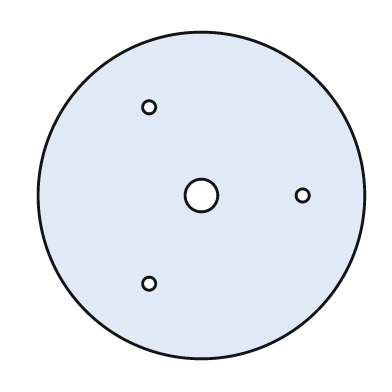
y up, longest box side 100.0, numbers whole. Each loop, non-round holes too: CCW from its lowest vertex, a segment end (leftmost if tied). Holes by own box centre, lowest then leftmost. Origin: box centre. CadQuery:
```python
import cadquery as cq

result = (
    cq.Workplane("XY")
    .moveTo(0.0, 0.0)
    .circle(50.0)
    .moveTo(-16.0, -27.0)
    .circle(2.0)
    .moveTo(0.0, 0.0)
    .circle(5.0)
    .moveTo(31.0, 0.0)
    .circle(2.0)
    .moveTo(-16.0, 27.0)
    .circle(2.0)
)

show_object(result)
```